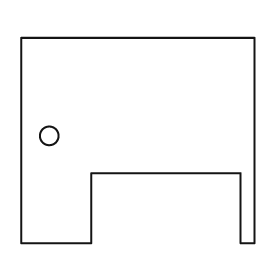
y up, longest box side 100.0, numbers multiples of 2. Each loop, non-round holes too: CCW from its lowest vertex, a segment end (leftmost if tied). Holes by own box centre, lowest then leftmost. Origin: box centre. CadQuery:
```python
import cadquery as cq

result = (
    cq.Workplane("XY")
    .moveTo(-50.0, -44.0)
    .lineTo(-20.0, -44.0)
    .lineTo(-20.0, -14.0)
    .lineTo(44.0, -14.0)
    .lineTo(44.0, -44.0)
    .lineTo(50.0, -44.0)
    .lineTo(50.0, 44.0)
    .lineTo(-50.0, 44.0)
    .close()
    .moveTo(-38.0, 2.0)
    .circle(4.0)
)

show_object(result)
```